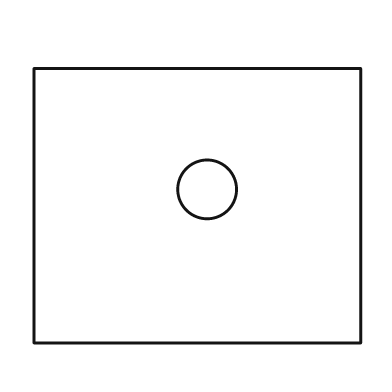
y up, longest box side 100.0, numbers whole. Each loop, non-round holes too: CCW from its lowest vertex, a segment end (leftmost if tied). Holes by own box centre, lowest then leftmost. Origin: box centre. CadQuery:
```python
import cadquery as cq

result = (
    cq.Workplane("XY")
    .moveTo(-50.0, -42.0)
    .lineTo(50.0, -42.0)
    .lineTo(50.0, 42.0)
    .lineTo(-50.0, 42.0)
    .close()
    .moveTo(3.0, 5.0)
    .circle(9.0)
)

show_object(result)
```